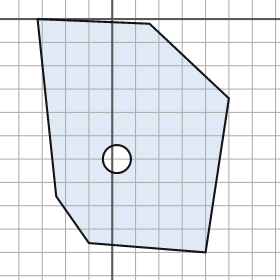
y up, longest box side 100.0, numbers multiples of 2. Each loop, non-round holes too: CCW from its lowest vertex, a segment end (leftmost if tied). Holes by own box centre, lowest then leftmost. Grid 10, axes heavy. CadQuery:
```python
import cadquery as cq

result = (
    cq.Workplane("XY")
    .moveTo(40.0, -100.0)
    .lineTo(50.0, -34.0)
    .lineTo(16.0, -2.0)
    .lineTo(-32.0, 0.0)
    .lineTo(-24.0, -76.0)
    .lineTo(-10.0, -96.0)
    .close()
    .moveTo(2.0, -60.0)
    .circle(6.0)
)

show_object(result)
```